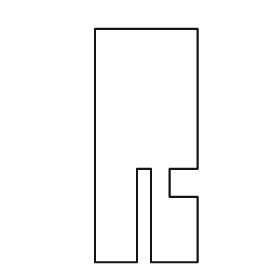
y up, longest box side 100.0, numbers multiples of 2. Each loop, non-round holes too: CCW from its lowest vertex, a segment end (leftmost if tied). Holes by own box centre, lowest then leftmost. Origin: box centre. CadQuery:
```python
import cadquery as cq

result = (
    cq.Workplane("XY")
    .moveTo(-22.0, -50.0)
    .lineTo(-4.0, -50.0)
    .lineTo(-4.0, -10.0)
    .lineTo(2.0, -10.0)
    .lineTo(2.0, -50.0)
    .lineTo(22.0, -50.0)
    .lineTo(22.0, -22.0)
    .lineTo(10.0, -22.0)
    .lineTo(10.0, -10.0)
    .lineTo(22.0, -10.0)
    .lineTo(22.0, 50.0)
    .lineTo(-22.0, 50.0)
    .close()
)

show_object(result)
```